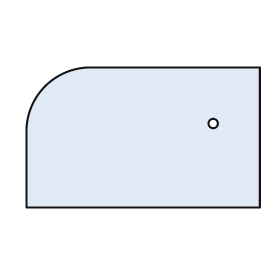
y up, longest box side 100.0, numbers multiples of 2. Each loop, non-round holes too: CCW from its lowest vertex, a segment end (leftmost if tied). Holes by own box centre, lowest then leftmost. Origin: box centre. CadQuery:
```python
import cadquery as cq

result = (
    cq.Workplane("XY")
    .moveTo(-50.0, -30.0)
    .lineTo(50.0, -30.0)
    .lineTo(50.0, 30.0)
    .lineTo(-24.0, 30.0)
    .threePointArc((-42.0, 22.0), (-50.0, 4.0))
    .close()
    .moveTo(30.0, 6.0)
    .circle(2.0)
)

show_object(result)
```